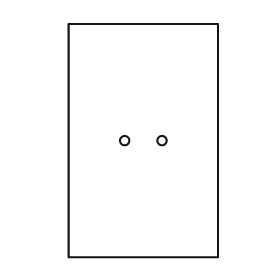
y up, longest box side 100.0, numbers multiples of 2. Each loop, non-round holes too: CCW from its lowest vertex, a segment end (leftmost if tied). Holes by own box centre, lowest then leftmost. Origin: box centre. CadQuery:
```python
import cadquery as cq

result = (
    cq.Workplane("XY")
    .moveTo(-32.0, -50.0)
    .lineTo(32.0, -50.0)
    .lineTo(32.0, 50.0)
    .lineTo(-32.0, 50.0)
    .close()
    .moveTo(-8.0, 0.0)
    .circle(2.0)
    .moveTo(8.0, 0.0)
    .circle(2.0)
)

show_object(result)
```